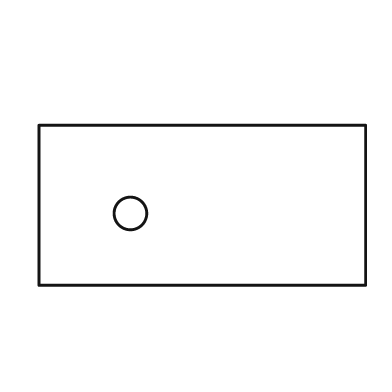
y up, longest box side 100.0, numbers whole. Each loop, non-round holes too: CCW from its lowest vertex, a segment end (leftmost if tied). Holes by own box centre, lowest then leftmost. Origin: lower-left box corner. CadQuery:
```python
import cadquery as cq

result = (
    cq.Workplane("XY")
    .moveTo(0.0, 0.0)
    .lineTo(100.0, 0.0)
    .lineTo(100.0, 49.0)
    .lineTo(0.0, 49.0)
    .close()
    .moveTo(28.0, 22.0)
    .circle(5.0)
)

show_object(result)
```